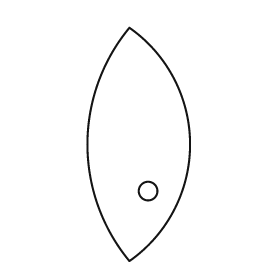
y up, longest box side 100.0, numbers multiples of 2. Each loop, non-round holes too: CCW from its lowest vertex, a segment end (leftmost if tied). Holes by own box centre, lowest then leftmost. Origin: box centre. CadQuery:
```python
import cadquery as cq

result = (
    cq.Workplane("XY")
    .moveTo(-4.0, -50.0)
    .threePointArc((22.0, 0.0), (-4.0, 50.0))
    .threePointArc((-22.0, 0.0), (-4.0, -50.0))
    .close()
    .moveTo(4.0, -20.0)
    .circle(4.0)
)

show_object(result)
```